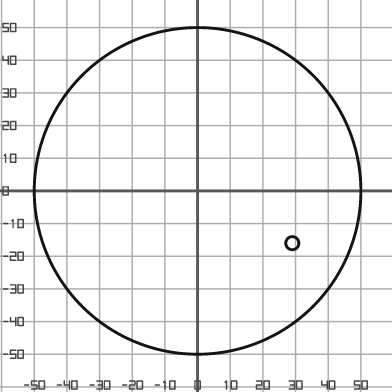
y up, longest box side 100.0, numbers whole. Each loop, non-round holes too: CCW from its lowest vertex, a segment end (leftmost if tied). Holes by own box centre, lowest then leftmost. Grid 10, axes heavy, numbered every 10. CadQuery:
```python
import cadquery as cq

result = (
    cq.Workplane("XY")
    .moveTo(0.0, 0.0)
    .circle(50.0)
    .moveTo(29.0, -16.0)
    .circle(2.0)
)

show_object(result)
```